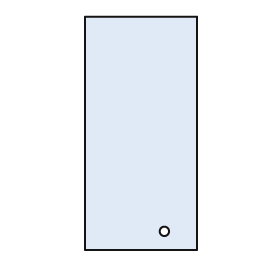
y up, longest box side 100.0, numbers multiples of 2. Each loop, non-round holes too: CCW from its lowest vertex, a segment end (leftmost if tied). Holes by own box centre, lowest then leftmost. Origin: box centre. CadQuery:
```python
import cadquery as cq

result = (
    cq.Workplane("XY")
    .moveTo(-24.0, -50.0)
    .lineTo(24.0, -50.0)
    .lineTo(24.0, 50.0)
    .lineTo(-24.0, 50.0)
    .close()
    .moveTo(10.0, -42.0)
    .circle(2.0)
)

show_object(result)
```